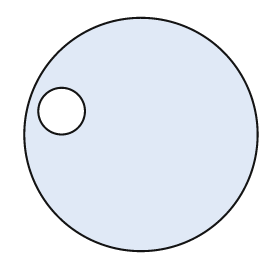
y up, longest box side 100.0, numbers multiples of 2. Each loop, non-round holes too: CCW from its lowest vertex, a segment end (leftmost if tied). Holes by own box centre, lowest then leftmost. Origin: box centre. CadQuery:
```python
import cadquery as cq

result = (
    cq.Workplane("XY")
    .moveTo(0.0, 0.0)
    .circle(50.0)
    .moveTo(-34.0, 10.0)
    .circle(10.0)
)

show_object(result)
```